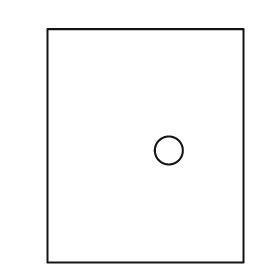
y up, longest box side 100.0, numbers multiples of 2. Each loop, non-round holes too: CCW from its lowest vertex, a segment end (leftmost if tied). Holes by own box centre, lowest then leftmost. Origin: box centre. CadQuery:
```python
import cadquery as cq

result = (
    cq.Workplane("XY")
    .moveTo(-42.0, -50.0)
    .lineTo(42.0, -50.0)
    .lineTo(42.0, 50.0)
    .lineTo(-42.0, 50.0)
    .close()
    .moveTo(10.0, -2.0)
    .circle(6.0)
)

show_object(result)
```